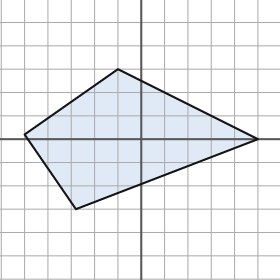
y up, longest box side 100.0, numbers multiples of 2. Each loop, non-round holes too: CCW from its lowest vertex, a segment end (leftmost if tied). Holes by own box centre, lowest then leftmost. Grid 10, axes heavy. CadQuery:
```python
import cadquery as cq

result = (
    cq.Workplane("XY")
    .moveTo(-28.0, -30.0)
    .lineTo(50.0, 0.0)
    .lineTo(-10.0, 30.0)
    .lineTo(-50.0, 2.0)
    .close()
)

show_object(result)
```